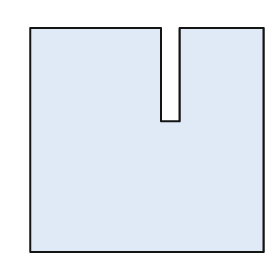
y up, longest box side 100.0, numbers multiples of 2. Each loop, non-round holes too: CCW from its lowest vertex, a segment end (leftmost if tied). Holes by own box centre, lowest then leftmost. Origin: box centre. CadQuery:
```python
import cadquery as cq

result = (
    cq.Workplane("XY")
    .moveTo(-50.0, -48.0)
    .lineTo(50.0, -48.0)
    .lineTo(50.0, 48.0)
    .lineTo(14.0, 48.0)
    .lineTo(14.0, 8.0)
    .lineTo(6.0, 8.0)
    .lineTo(6.0, 48.0)
    .lineTo(-50.0, 48.0)
    .close()
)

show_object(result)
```